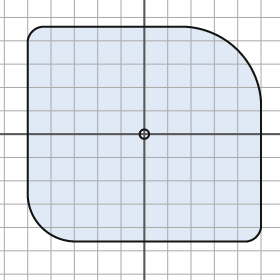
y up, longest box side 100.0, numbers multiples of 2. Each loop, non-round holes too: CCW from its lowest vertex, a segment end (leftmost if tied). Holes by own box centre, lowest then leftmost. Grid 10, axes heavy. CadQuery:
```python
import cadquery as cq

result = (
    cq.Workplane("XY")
    .moveTo(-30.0, -46.0)
    .lineTo(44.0, -46.0)
    .threePointArc((48.0, -44.0), (50.0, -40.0))
    .lineTo(50.0, 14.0)
    .threePointArc((40.0, 36.0), (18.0, 46.0))
    .lineTo(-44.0, 46.0)
    .threePointArc((-48.0, 44.0), (-50.0, 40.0))
    .lineTo(-50.0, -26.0)
    .threePointArc((-44.0, -40.0), (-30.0, -46.0))
    .close()
    .moveTo(0.0, 0.0)
    .circle(2.0)
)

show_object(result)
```